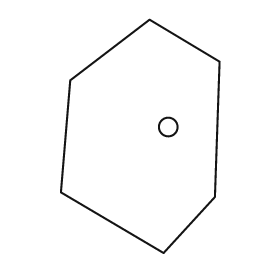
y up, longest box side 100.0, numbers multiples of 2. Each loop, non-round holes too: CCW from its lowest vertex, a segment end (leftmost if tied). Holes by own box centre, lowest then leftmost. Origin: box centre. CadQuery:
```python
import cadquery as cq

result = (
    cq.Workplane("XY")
    .moveTo(10.0, -50.0)
    .lineTo(32.0, -26.0)
    .lineTo(34.0, 32.0)
    .lineTo(4.0, 50.0)
    .lineTo(-30.0, 24.0)
    .lineTo(-34.0, -24.0)
    .close()
    .moveTo(12.0, 4.0)
    .circle(4.0)
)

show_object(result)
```